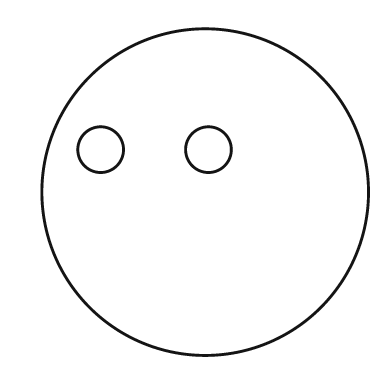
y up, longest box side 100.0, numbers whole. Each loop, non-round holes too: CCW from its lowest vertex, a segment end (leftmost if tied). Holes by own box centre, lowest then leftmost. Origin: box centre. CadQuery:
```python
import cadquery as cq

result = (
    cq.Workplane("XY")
    .moveTo(0.0, 0.0)
    .circle(50.0)
    .moveTo(-32.0, 13.0)
    .circle(7.0)
    .moveTo(1.0, 13.0)
    .circle(7.0)
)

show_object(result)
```